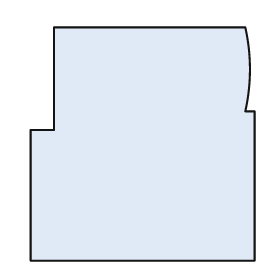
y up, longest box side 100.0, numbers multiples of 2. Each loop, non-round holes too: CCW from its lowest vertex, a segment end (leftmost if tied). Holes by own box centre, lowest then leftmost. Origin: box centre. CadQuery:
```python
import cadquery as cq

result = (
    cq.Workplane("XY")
    .moveTo(-48.0, -50.0)
    .lineTo(48.0, -50.0)
    .lineTo(48.0, 14.0)
    .lineTo(44.0, 14.0)
    .threePointArc((46.0, 32.0), (44.0, 50.0))
    .lineTo(-38.0, 50.0)
    .lineTo(-38.0, 6.0)
    .lineTo(-48.0, 6.0)
    .close()
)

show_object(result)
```